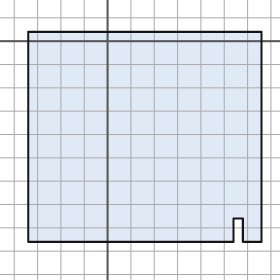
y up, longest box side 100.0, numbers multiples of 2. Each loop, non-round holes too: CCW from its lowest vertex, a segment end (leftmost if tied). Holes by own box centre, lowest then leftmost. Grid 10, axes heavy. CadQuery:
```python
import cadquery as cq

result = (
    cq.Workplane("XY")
    .moveTo(-34.0, -86.0)
    .lineTo(54.0, -86.0)
    .lineTo(54.0, -76.0)
    .lineTo(58.0, -76.0)
    .lineTo(58.0, -86.0)
    .lineTo(66.0, -86.0)
    .lineTo(66.0, 4.0)
    .lineTo(-34.0, 4.0)
    .close()
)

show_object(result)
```